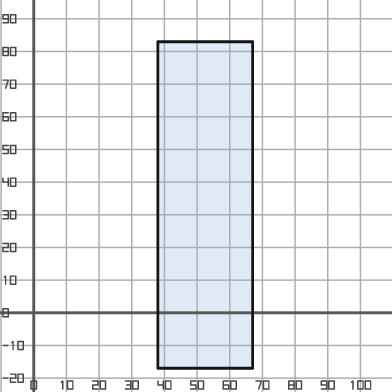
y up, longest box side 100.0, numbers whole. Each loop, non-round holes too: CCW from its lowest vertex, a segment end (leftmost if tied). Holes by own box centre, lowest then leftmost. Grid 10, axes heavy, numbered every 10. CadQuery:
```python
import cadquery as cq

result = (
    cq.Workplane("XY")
    .moveTo(38.0, -17.0)
    .lineTo(67.0, -17.0)
    .lineTo(67.0, 83.0)
    .lineTo(38.0, 83.0)
    .close()
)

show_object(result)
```